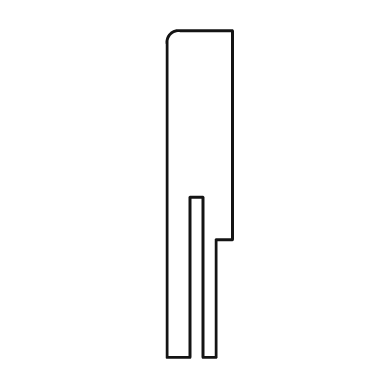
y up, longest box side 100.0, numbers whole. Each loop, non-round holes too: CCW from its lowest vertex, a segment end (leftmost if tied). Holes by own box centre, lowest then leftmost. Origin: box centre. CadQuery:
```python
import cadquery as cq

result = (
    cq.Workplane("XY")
    .moveTo(-10.0, -50.0)
    .lineTo(-3.0, -50.0)
    .lineTo(-3.0, -1.0)
    .lineTo(1.0, -1.0)
    .lineTo(1.0, -50.0)
    .lineTo(5.0, -50.0)
    .lineTo(5.0, -14.0)
    .lineTo(10.0, -14.0)
    .lineTo(10.0, 50.0)
    .lineTo(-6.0, 50.0)
    .threePointArc((-9.0, 49.0), (-10.0, 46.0))
    .close()
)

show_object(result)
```